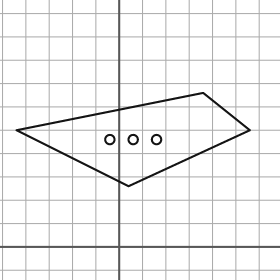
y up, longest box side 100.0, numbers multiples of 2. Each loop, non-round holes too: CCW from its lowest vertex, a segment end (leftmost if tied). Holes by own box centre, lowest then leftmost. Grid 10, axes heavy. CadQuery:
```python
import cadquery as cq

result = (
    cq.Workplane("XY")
    .moveTo(4.0, 26.0)
    .lineTo(56.0, 50.0)
    .lineTo(36.0, 66.0)
    .lineTo(-44.0, 50.0)
    .close()
    .moveTo(-4.0, 46.0)
    .circle(2.0)
    .moveTo(6.0, 46.0)
    .circle(2.0)
    .moveTo(16.0, 46.0)
    .circle(2.0)
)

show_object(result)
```